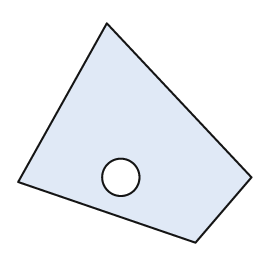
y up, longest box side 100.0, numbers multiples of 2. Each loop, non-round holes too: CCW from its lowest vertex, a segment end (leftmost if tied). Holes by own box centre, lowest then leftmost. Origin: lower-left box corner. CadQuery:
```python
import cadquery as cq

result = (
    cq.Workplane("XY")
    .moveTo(76.0, 0.0)
    .lineTo(100.0, 28.0)
    .lineTo(38.0, 94.0)
    .lineTo(0.0, 26.0)
    .close()
    .moveTo(44.0, 28.0)
    .circle(8.0)
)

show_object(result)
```